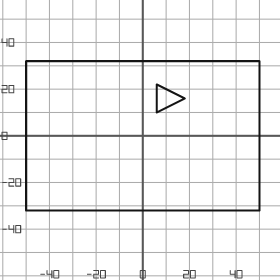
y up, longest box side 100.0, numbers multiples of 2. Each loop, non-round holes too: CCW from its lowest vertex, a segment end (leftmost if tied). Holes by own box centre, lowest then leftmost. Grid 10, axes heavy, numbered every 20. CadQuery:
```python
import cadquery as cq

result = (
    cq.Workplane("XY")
    .moveTo(-50.0, -32.0)
    .lineTo(50.0, -32.0)
    .lineTo(50.0, 32.0)
    .lineTo(-50.0, 32.0)
    .close()
    .moveTo(6.0, 10.0)
    .lineTo(18.0, 16.0)
    .lineTo(6.0, 22.0)
    .close()
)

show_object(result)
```